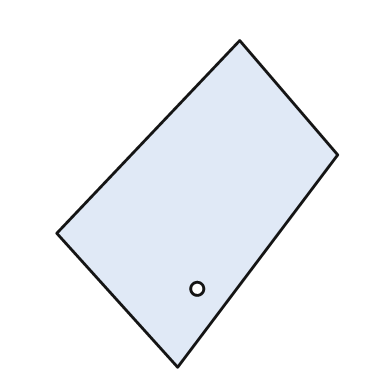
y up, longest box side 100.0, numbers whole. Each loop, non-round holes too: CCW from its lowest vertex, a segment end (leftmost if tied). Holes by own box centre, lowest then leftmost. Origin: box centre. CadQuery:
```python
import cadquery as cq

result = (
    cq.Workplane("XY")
    .moveTo(-6.0, -50.0)
    .lineTo(43.0, 15.0)
    .lineTo(13.0, 50.0)
    .lineTo(-43.0, -9.0)
    .close()
    .moveTo(0.0, -26.0)
    .circle(2.0)
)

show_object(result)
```